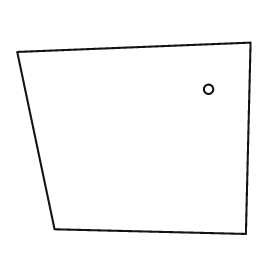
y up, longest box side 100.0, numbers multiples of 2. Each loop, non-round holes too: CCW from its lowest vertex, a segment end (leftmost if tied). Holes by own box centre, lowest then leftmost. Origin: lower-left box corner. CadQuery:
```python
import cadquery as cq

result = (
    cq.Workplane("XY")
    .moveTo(98.0, 0.0)
    .lineTo(100.0, 82.0)
    .lineTo(0.0, 78.0)
    .lineTo(16.0, 2.0)
    .close()
    .moveTo(82.0, 62.0)
    .circle(2.0)
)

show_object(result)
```